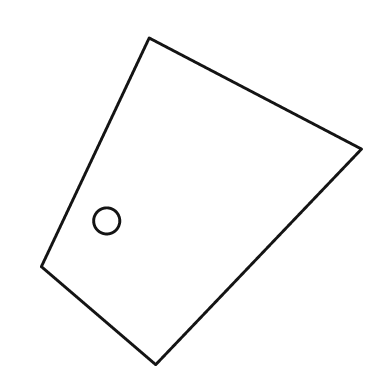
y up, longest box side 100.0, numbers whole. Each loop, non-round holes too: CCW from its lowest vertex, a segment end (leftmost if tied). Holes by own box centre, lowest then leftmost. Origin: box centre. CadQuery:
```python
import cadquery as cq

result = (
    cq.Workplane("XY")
    .moveTo(-14.0, -50.0)
    .lineTo(49.0, 16.0)
    .lineTo(-16.0, 50.0)
    .lineTo(-49.0, -20.0)
    .close()
    .moveTo(-29.0, -6.0)
    .circle(4.0)
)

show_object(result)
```